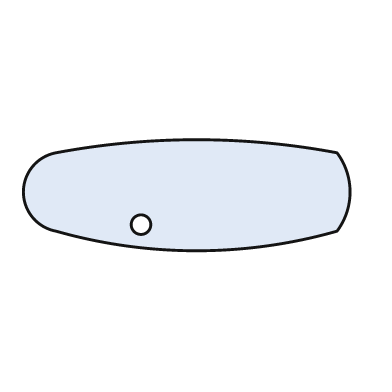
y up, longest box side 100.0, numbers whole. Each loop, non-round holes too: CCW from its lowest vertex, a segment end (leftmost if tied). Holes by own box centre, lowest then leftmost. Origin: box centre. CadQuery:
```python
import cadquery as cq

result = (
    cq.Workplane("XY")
    .moveTo(-40.0, -11.0)
    .threePointArc((3.0, -17.0), (46.0, -11.0))
    .threePointArc((50.0, 1.0), (46.0, 13.0))
    .threePointArc((3.0, 17.0), (-40.0, 13.0))
    .threePointArc((-50.0, 1.0), (-40.0, -11.0))
    .close()
    .moveTo(-14.0, -9.0)
    .circle(3.0)
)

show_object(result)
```